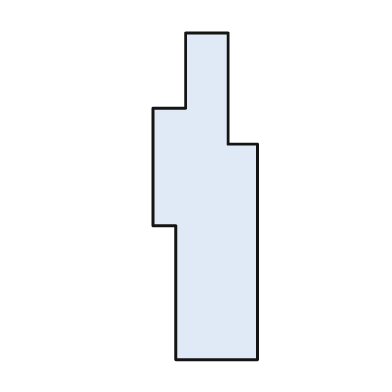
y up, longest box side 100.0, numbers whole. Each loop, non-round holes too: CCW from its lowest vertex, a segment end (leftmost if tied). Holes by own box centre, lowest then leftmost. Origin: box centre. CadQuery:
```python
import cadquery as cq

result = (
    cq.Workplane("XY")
    .moveTo(-9.0, -50.0)
    .lineTo(16.0, -50.0)
    .lineTo(16.0, 16.0)
    .lineTo(7.0, 16.0)
    .lineTo(7.0, 50.0)
    .lineTo(-6.0, 50.0)
    .lineTo(-6.0, 27.0)
    .lineTo(-16.0, 27.0)
    .lineTo(-16.0, -9.0)
    .lineTo(-9.0, -9.0)
    .close()
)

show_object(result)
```